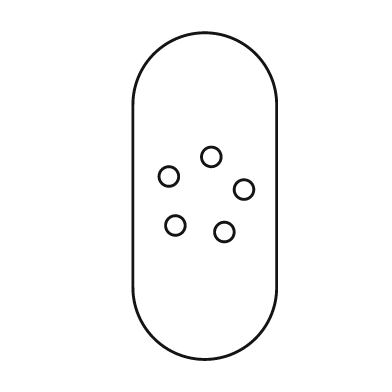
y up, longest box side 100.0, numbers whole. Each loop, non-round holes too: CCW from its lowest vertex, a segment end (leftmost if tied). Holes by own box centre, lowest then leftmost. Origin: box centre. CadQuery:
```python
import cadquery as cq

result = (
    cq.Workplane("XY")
    .moveTo(-22.0, -28.0)
    .threePointArc((0.0, -50.0), (22.0, -28.0))
    .lineTo(22.0, 28.0)
    .threePointArc((0.0, 50.0), (-22.0, 28.0))
    .close()
    .moveTo(6.0, -11.0)
    .circle(3.0)
    .moveTo(-9.0, -9.0)
    .circle(3.0)
    .moveTo(12.0, 2.0)
    .circle(3.0)
    .moveTo(-11.0, 6.0)
    .circle(3.0)
    .moveTo(2.0, 12.0)
    .circle(3.0)
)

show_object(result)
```